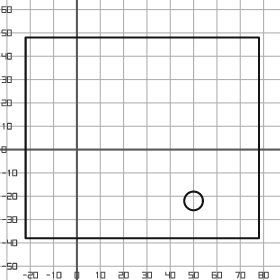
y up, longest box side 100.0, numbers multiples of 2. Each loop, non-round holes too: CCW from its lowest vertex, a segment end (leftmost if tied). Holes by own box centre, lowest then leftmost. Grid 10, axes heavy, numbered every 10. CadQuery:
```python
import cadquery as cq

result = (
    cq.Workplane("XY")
    .moveTo(-22.0, -38.0)
    .lineTo(78.0, -38.0)
    .lineTo(78.0, 48.0)
    .lineTo(-22.0, 48.0)
    .close()
    .moveTo(50.0, -22.0)
    .circle(4.0)
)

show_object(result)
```